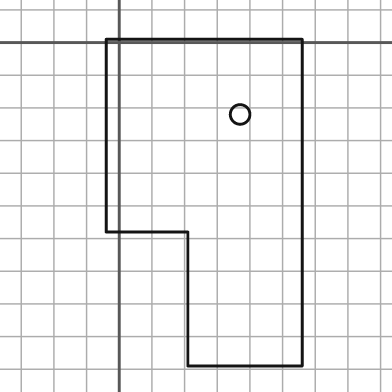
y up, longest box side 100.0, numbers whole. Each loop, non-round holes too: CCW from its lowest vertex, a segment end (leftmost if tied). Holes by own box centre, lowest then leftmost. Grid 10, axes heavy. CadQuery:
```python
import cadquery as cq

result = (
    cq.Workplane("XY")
    .moveTo(21.0, -99.0)
    .lineTo(56.0, -99.0)
    .lineTo(56.0, 1.0)
    .lineTo(-4.0, 1.0)
    .lineTo(-4.0, -58.0)
    .lineTo(21.0, -58.0)
    .close()
    .moveTo(37.0, -22.0)
    .circle(3.0)
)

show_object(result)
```